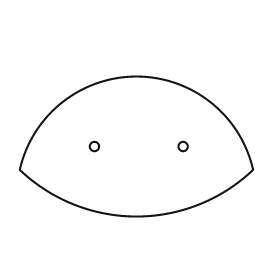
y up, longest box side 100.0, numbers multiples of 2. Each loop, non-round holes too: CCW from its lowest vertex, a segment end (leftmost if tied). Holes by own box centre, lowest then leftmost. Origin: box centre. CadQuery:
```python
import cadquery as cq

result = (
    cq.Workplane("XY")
    .moveTo(-50.0, -10.0)
    .threePointArc((0.0, -30.0), (50.0, -10.0))
    .threePointArc((0.0, 30.0), (-50.0, -10.0))
    .close()
    .moveTo(-18.0, 0.0)
    .circle(2.0)
    .moveTo(20.0, 0.0)
    .circle(2.0)
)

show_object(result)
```